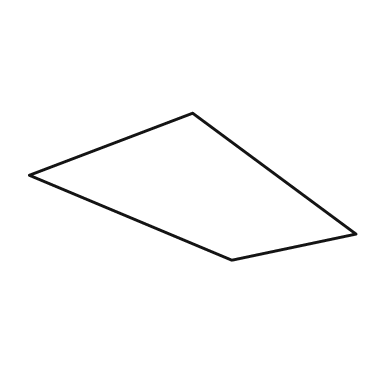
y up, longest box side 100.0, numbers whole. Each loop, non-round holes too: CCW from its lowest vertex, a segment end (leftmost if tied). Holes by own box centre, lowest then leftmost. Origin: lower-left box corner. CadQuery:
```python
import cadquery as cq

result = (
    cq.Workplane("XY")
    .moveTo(62.0, 0.0)
    .lineTo(100.0, 8.0)
    .lineTo(50.0, 45.0)
    .lineTo(0.0, 26.0)
    .close()
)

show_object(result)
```